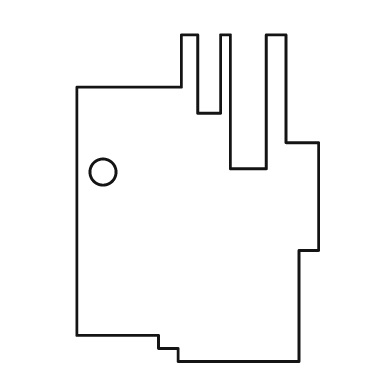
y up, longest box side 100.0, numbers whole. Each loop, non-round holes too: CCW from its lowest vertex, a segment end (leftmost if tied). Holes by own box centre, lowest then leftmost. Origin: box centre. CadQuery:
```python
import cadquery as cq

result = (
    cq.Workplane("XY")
    .moveTo(-6.0, -50.0)
    .lineTo(31.0, -50.0)
    .lineTo(31.0, -16.0)
    .lineTo(37.0, -16.0)
    .lineTo(37.0, 17.0)
    .lineTo(27.0, 17.0)
    .lineTo(27.0, 50.0)
    .lineTo(21.0, 50.0)
    .lineTo(21.0, 9.0)
    .lineTo(10.0, 9.0)
    .lineTo(10.0, 50.0)
    .lineTo(7.0, 50.0)
    .lineTo(7.0, 26.0)
    .lineTo(0.0, 26.0)
    .lineTo(0.0, 50.0)
    .lineTo(-5.0, 50.0)
    .lineTo(-5.0, 34.0)
    .lineTo(-37.0, 34.0)
    .lineTo(-37.0, -42.0)
    .lineTo(-12.0, -42.0)
    .lineTo(-12.0, -46.0)
    .lineTo(-6.0, -46.0)
    .close()
    .moveTo(-29.0, 8.0)
    .circle(4.0)
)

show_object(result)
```